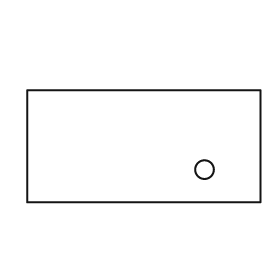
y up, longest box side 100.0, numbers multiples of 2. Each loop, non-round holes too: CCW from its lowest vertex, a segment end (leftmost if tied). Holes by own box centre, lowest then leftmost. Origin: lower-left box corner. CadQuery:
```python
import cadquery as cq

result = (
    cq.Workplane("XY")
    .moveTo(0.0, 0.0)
    .lineTo(100.0, 0.0)
    .lineTo(100.0, 48.0)
    .lineTo(0.0, 48.0)
    .close()
    .moveTo(76.0, 14.0)
    .circle(4.0)
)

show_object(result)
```